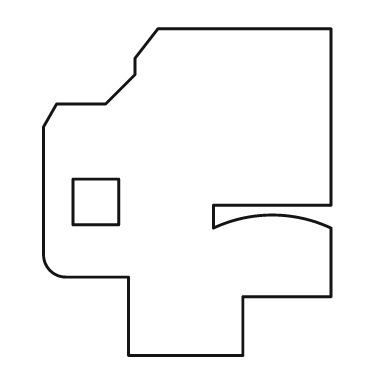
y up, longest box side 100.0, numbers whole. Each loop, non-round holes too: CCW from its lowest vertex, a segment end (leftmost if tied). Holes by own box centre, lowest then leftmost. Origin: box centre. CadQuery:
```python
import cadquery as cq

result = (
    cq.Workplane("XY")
    .moveTo(-18.0, -50.0)
    .lineTo(17.0, -50.0)
    .lineTo(17.0, -32.0)
    .lineTo(44.0, -32.0)
    .lineTo(44.0, -11.0)
    .threePointArc((26.0, -7.0), (8.0, -11.0))
    .lineTo(8.0, -4.0)
    .lineTo(44.0, -4.0)
    .lineTo(44.0, 50.0)
    .lineTo(-9.0, 50.0)
    .lineTo(-16.0, 41.0)
    .lineTo(-16.0, 36.0)
    .lineTo(-25.0, 27.0)
    .lineTo(-40.0, 27.0)
    .lineTo(-44.0, 20.0)
    .lineTo(-44.0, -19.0)
    .threePointArc((-42.0, -24.0), (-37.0, -26.0))
    .lineTo(-18.0, -26.0)
    .close()
    .moveTo(-35.0, -10.0)
    .lineTo(-21.0, -10.0)
    .lineTo(-21.0, 4.0)
    .lineTo(-35.0, 4.0)
    .close()
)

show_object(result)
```